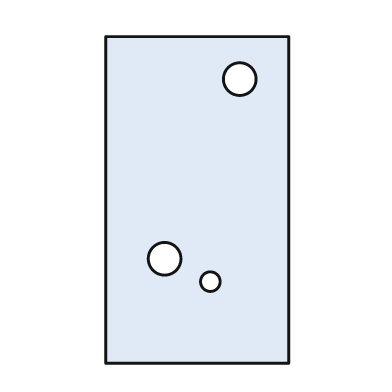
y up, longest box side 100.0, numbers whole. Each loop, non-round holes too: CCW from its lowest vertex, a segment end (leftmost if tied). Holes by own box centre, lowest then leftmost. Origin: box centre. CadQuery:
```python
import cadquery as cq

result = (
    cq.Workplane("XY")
    .moveTo(-28.0, -50.0)
    .lineTo(28.0, -50.0)
    .lineTo(28.0, 50.0)
    .lineTo(-28.0, 50.0)
    .close()
    .moveTo(4.0, -25.0)
    .circle(3.0)
    .moveTo(-10.0, -18.0)
    .circle(5.0)
    .moveTo(13.0, 37.0)
    .circle(5.0)
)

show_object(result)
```